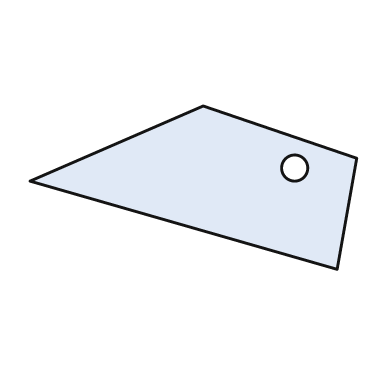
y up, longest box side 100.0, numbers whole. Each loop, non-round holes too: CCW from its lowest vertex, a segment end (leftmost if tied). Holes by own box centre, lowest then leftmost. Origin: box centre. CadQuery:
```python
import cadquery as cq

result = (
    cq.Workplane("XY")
    .moveTo(44.0, -25.0)
    .lineTo(50.0, 9.0)
    .lineTo(3.0, 25.0)
    .lineTo(-50.0, 2.0)
    .close()
    .moveTo(31.0, 6.0)
    .circle(4.0)
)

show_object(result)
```